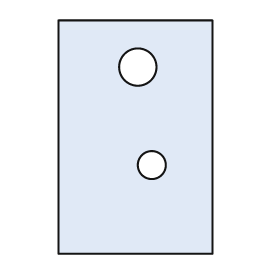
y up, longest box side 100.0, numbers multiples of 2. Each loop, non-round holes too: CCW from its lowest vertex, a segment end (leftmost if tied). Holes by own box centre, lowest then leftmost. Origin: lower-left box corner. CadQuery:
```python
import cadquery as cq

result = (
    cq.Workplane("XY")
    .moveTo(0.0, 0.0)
    .lineTo(66.0, 0.0)
    .lineTo(66.0, 100.0)
    .lineTo(0.0, 100.0)
    .close()
    .moveTo(40.0, 38.0)
    .circle(6.0)
    .moveTo(34.0, 80.0)
    .circle(8.0)
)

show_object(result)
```